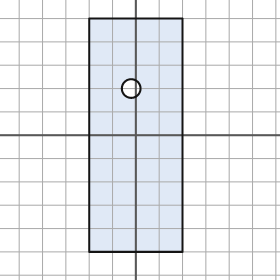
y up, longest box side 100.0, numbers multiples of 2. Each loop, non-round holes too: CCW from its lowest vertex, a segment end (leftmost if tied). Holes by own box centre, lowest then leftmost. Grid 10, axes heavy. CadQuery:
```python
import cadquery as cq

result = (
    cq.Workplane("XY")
    .moveTo(-20.0, -50.0)
    .lineTo(20.0, -50.0)
    .lineTo(20.0, 50.0)
    .lineTo(-20.0, 50.0)
    .close()
    .moveTo(-2.0, 20.0)
    .circle(4.0)
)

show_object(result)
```